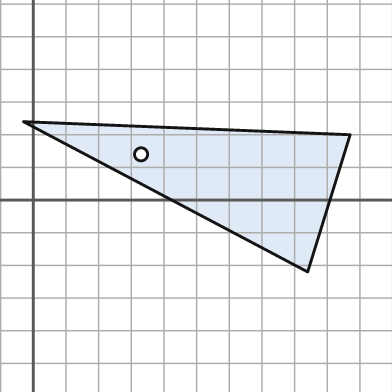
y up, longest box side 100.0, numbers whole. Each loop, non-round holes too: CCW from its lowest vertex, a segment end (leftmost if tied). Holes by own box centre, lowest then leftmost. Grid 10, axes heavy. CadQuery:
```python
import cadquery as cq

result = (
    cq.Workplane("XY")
    .moveTo(84.0, -22.0)
    .lineTo(97.0, 20.0)
    .lineTo(-3.0, 24.0)
    .close()
    .moveTo(33.0, 14.0)
    .circle(2.0)
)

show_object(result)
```